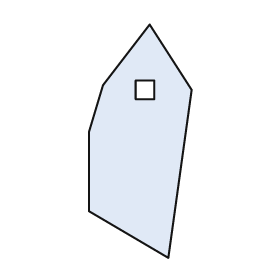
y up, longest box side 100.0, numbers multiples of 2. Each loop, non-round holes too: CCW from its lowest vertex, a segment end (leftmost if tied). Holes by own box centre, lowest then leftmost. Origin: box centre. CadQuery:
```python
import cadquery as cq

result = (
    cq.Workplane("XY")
    .moveTo(12.0, -50.0)
    .lineTo(22.0, 22.0)
    .lineTo(4.0, 50.0)
    .lineTo(-16.0, 24.0)
    .lineTo(-22.0, 4.0)
    .lineTo(-22.0, -30.0)
    .close()
    .moveTo(-2.0, 18.0)
    .lineTo(6.0, 18.0)
    .lineTo(6.0, 26.0)
    .lineTo(-2.0, 26.0)
    .close()
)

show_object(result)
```